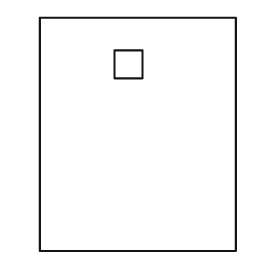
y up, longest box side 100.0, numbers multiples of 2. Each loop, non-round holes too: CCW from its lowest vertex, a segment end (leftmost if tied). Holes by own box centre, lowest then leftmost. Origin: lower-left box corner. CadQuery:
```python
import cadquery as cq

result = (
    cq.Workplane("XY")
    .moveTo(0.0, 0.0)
    .lineTo(84.0, 0.0)
    .lineTo(84.0, 100.0)
    .lineTo(0.0, 100.0)
    .close()
    .moveTo(32.0, 74.0)
    .lineTo(44.0, 74.0)
    .lineTo(44.0, 86.0)
    .lineTo(32.0, 86.0)
    .close()
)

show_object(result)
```